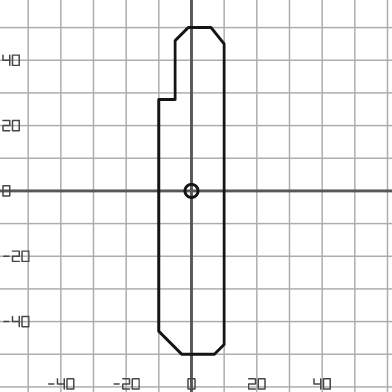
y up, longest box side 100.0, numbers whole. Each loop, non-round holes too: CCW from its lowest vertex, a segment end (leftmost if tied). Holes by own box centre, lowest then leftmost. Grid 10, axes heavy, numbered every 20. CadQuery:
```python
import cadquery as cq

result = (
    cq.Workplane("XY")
    .moveTo(-3.0, -50.0)
    .lineTo(7.0, -50.0)
    .lineTo(10.0, -47.0)
    .lineTo(10.0, 45.0)
    .lineTo(6.0, 50.0)
    .lineTo(-1.0, 50.0)
    .lineTo(-5.0, 46.0)
    .lineTo(-5.0, 28.0)
    .lineTo(-10.0, 28.0)
    .lineTo(-10.0, -43.0)
    .close()
    .moveTo(0.0, 0.0)
    .circle(2.0)
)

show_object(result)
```